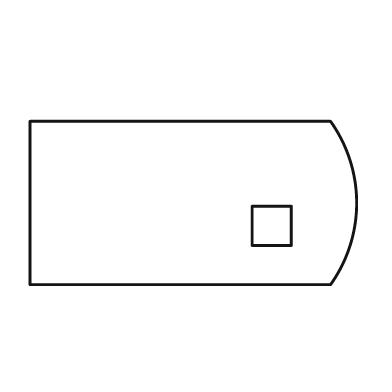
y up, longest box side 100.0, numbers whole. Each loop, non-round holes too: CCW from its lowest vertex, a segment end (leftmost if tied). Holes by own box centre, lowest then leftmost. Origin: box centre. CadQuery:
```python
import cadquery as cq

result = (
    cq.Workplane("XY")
    .moveTo(-50.0, -25.0)
    .lineTo(42.0, -25.0)
    .threePointArc((50.0, 0.0), (42.0, 25.0))
    .lineTo(-50.0, 25.0)
    .close()
    .moveTo(18.0, -13.0)
    .lineTo(30.0, -13.0)
    .lineTo(30.0, -1.0)
    .lineTo(18.0, -1.0)
    .close()
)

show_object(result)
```